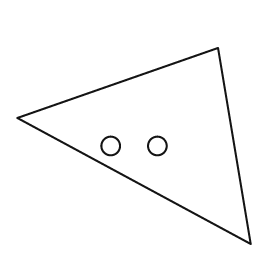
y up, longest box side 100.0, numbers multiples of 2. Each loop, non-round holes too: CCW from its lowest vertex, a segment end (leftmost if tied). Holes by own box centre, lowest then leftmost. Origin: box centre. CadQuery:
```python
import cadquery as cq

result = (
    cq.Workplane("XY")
    .moveTo(50.0, -42.0)
    .lineTo(36.0, 42.0)
    .lineTo(-50.0, 12.0)
    .close()
    .moveTo(-10.0, 0.0)
    .circle(4.0)
    .moveTo(10.0, 0.0)
    .circle(4.0)
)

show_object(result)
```